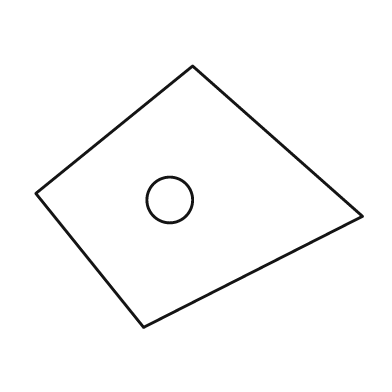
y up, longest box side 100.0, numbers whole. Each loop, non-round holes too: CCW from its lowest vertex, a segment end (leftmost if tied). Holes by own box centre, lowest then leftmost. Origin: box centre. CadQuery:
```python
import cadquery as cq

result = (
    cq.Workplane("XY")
    .moveTo(-17.0, -40.0)
    .lineTo(50.0, -6.0)
    .lineTo(-2.0, 40.0)
    .lineTo(-50.0, 1.0)
    .close()
    .moveTo(-9.0, -1.0)
    .circle(7.0)
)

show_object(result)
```